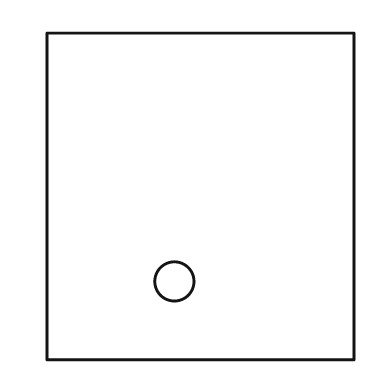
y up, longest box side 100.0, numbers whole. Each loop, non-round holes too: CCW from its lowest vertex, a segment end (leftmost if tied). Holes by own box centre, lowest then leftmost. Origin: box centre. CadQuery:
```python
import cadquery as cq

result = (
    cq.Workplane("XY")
    .moveTo(-47.0, -50.0)
    .lineTo(47.0, -50.0)
    .lineTo(47.0, 50.0)
    .lineTo(-47.0, 50.0)
    .close()
    .moveTo(-8.0, -26.0)
    .circle(6.0)
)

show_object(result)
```